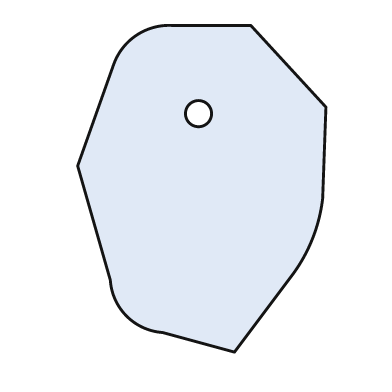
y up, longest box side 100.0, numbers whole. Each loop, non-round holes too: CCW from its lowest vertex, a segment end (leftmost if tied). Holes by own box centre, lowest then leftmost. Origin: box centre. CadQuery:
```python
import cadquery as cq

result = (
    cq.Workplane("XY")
    .moveTo(10.0, -50.0)
    .lineTo(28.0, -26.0)
    .threePointArc((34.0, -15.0), (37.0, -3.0))
    .lineTo(38.0, 25.0)
    .lineTo(15.0, 50.0)
    .lineTo(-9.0, 50.0)
    .threePointArc((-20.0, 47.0), (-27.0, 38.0))
    .lineTo(-38.0, 7.0)
    .lineTo(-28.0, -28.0)
    .threePointArc((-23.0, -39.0), (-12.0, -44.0))
    .close()
    .moveTo(-1.0, 23.0)
    .circle(4.0)
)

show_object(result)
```